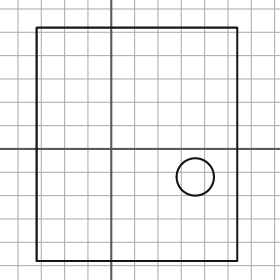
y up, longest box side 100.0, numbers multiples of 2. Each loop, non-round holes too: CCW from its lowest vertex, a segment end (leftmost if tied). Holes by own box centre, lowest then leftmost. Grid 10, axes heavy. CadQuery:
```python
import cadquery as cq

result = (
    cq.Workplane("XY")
    .moveTo(-32.0, -48.0)
    .lineTo(54.0, -48.0)
    .lineTo(54.0, 52.0)
    .lineTo(-32.0, 52.0)
    .close()
    .moveTo(36.0, -12.0)
    .circle(8.0)
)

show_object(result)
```